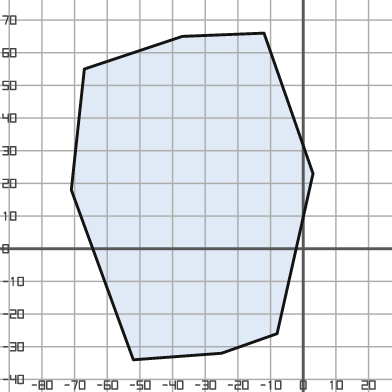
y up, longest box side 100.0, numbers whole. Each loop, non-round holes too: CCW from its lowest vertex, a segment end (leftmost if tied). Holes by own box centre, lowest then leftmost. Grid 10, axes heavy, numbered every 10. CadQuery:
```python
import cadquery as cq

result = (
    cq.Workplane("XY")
    .moveTo(-52.0, -34.0)
    .lineTo(-25.0, -32.0)
    .lineTo(-8.0, -26.0)
    .lineTo(3.0, 23.0)
    .lineTo(-12.0, 66.0)
    .lineTo(-37.0, 65.0)
    .lineTo(-67.0, 55.0)
    .lineTo(-71.0, 18.0)
    .close()
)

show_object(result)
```